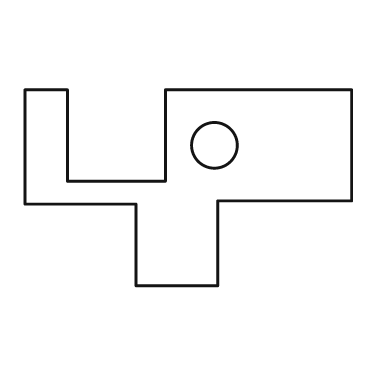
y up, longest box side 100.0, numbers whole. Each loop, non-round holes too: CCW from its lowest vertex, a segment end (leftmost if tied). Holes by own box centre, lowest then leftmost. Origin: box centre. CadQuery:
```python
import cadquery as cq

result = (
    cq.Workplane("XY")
    .moveTo(-16.0, -30.0)
    .lineTo(9.0, -30.0)
    .lineTo(9.0, -4.0)
    .lineTo(50.0, -4.0)
    .lineTo(50.0, 30.0)
    .lineTo(-7.0, 30.0)
    .lineTo(-7.0, 2.0)
    .lineTo(-37.0, 2.0)
    .lineTo(-37.0, 30.0)
    .lineTo(-50.0, 30.0)
    .lineTo(-50.0, -5.0)
    .lineTo(-16.0, -5.0)
    .close()
    .moveTo(8.0, 13.0)
    .circle(7.0)
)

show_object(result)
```